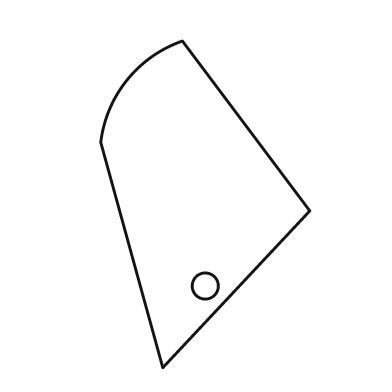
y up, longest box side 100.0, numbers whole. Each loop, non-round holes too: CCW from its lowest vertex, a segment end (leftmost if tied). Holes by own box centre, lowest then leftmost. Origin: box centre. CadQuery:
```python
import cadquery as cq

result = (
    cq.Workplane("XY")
    .moveTo(-13.0, -50.0)
    .lineTo(32.0, -2.0)
    .lineTo(-7.0, 50.0)
    .threePointArc((-24.0, 38.0), (-32.0, 19.0))
    .close()
    .moveTo(0.0, -25.0)
    .circle(4.0)
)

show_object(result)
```